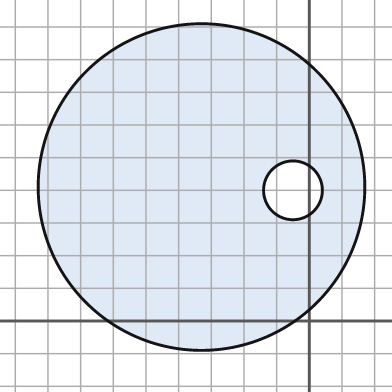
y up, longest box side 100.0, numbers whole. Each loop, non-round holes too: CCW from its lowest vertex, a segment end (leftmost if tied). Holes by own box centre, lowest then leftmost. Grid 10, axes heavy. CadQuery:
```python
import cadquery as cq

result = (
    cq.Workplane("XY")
    .moveTo(-33.0, 41.0)
    .circle(50.0)
    .moveTo(-5.0, 40.0)
    .circle(9.0)
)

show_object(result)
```